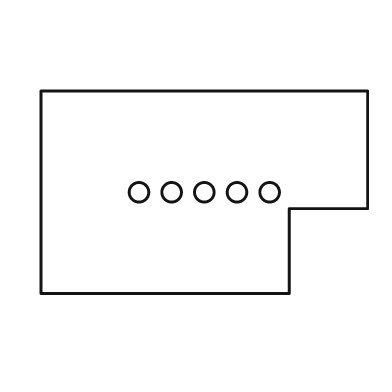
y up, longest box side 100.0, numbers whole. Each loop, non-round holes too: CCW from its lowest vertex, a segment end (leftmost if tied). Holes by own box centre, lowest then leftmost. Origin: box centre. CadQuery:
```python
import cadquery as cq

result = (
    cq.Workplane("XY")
    .moveTo(-50.0, -31.0)
    .lineTo(26.0, -31.0)
    .lineTo(26.0, -5.0)
    .lineTo(50.0, -5.0)
    .lineTo(50.0, 31.0)
    .lineTo(-50.0, 31.0)
    .close()
    .moveTo(-20.0, 0.0)
    .circle(3.0)
    .moveTo(-10.0, 0.0)
    .circle(3.0)
    .moveTo(0.0, 0.0)
    .circle(3.0)
    .moveTo(10.0, 0.0)
    .circle(3.0)
    .moveTo(20.0, 0.0)
    .circle(3.0)
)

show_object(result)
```